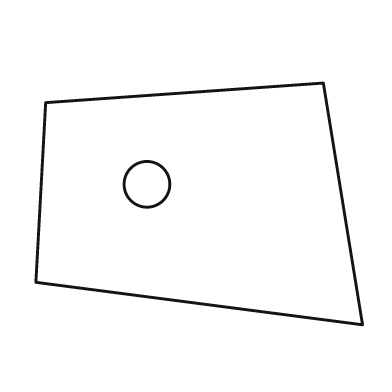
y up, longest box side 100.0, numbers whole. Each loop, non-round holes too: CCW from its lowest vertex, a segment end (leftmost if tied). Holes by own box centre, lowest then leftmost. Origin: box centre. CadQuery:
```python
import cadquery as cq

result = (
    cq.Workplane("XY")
    .moveTo(50.0, -37.0)
    .lineTo(38.0, 37.0)
    .lineTo(-47.0, 31.0)
    .lineTo(-50.0, -24.0)
    .close()
    .moveTo(-16.0, 6.0)
    .circle(7.0)
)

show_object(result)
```